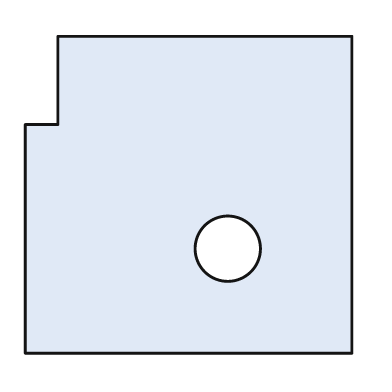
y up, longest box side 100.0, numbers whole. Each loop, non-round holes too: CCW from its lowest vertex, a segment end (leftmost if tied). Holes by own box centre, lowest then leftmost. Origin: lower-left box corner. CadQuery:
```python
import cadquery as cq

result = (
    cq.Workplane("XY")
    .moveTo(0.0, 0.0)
    .lineTo(100.0, 0.0)
    .lineTo(100.0, 97.0)
    .lineTo(10.0, 97.0)
    .lineTo(10.0, 70.0)
    .lineTo(0.0, 70.0)
    .close()
    .moveTo(62.0, 32.0)
    .circle(10.0)
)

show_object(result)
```